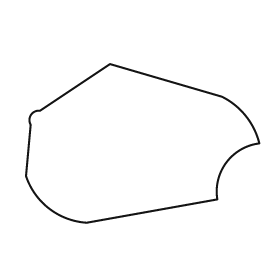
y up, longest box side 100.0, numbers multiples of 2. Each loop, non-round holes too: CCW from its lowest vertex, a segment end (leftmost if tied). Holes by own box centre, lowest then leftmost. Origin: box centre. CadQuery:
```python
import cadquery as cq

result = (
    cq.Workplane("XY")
    .moveTo(-24.0, -34.0)
    .lineTo(32.0, -24.0)
    .threePointArc((36.0, -8.0), (50.0, 0.0))
    .threePointArc((44.0, 12.0), (34.0, 20.0))
    .lineTo(-14.0, 34.0)
    .lineTo(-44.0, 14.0)
    .threePointArc((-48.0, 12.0), (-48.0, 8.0))
    .lineTo(-50.0, -14.0)
    .threePointArc((-40.0, -28.0), (-24.0, -34.0))
    .close()
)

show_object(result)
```